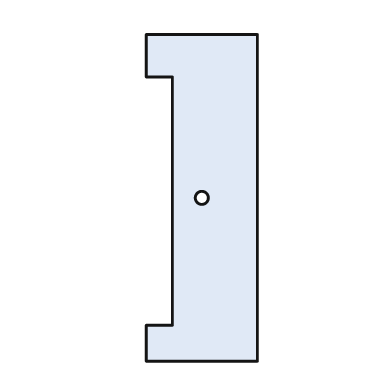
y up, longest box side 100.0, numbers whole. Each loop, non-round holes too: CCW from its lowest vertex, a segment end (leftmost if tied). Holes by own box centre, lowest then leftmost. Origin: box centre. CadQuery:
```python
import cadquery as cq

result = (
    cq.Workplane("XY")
    .moveTo(-17.0, -50.0)
    .lineTo(17.0, -50.0)
    .lineTo(17.0, 50.0)
    .lineTo(-17.0, 50.0)
    .lineTo(-17.0, 37.0)
    .lineTo(-9.0, 37.0)
    .lineTo(-9.0, -39.0)
    .lineTo(-17.0, -39.0)
    .close()
    .moveTo(0.0, 0.0)
    .circle(2.0)
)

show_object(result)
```